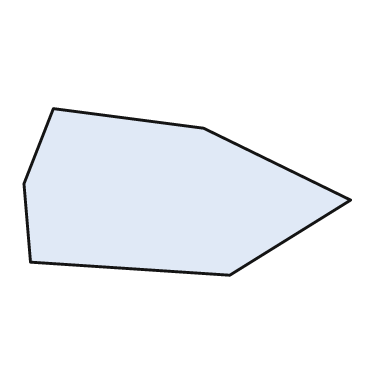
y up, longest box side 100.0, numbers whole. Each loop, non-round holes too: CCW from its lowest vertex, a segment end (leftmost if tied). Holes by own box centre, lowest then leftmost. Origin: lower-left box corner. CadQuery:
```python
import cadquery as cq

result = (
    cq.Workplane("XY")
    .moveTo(63.0, 0.0)
    .lineTo(100.0, 23.0)
    .lineTo(55.0, 45.0)
    .lineTo(9.0, 51.0)
    .lineTo(0.0, 28.0)
    .lineTo(2.0, 4.0)
    .close()
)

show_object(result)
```